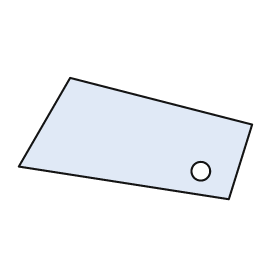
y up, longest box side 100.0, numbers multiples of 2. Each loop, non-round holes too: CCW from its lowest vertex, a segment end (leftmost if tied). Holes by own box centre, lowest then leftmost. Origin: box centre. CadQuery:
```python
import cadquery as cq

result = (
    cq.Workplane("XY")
    .moveTo(40.0, -26.0)
    .lineTo(50.0, 6.0)
    .lineTo(-28.0, 26.0)
    .lineTo(-50.0, -12.0)
    .close()
    .moveTo(28.0, -14.0)
    .circle(4.0)
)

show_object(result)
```